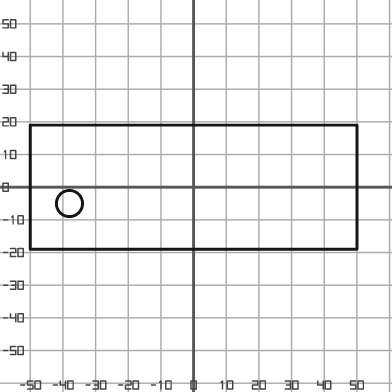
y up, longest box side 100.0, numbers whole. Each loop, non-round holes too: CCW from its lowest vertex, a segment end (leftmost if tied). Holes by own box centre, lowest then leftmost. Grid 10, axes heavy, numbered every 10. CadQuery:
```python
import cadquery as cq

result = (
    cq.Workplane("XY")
    .moveTo(-50.0, -19.0)
    .lineTo(50.0, -19.0)
    .lineTo(50.0, 19.0)
    .lineTo(-50.0, 19.0)
    .close()
    .moveTo(-38.0, -5.0)
    .circle(4.0)
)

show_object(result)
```